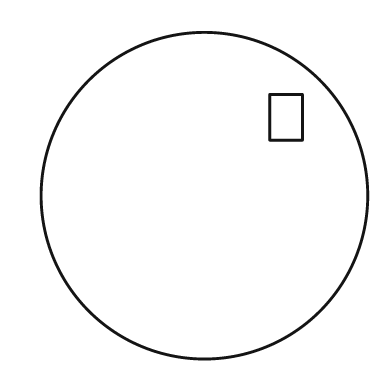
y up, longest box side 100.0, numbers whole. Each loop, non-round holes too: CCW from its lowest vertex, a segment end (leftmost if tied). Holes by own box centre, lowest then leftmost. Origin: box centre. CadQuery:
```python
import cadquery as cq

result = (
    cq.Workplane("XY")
    .moveTo(0.0, 0.0)
    .circle(50.0)
    .moveTo(20.0, 17.0)
    .lineTo(30.0, 17.0)
    .lineTo(30.0, 31.0)
    .lineTo(20.0, 31.0)
    .close()
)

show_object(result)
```